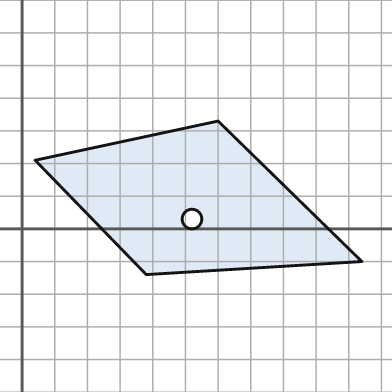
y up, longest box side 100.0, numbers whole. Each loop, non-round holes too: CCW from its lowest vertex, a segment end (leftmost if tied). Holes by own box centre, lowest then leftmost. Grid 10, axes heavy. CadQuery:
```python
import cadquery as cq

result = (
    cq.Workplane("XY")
    .moveTo(38.0, -14.0)
    .lineTo(104.0, -10.0)
    .lineTo(60.0, 33.0)
    .lineTo(4.0, 21.0)
    .close()
    .moveTo(52.0, 3.0)
    .circle(3.0)
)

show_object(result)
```